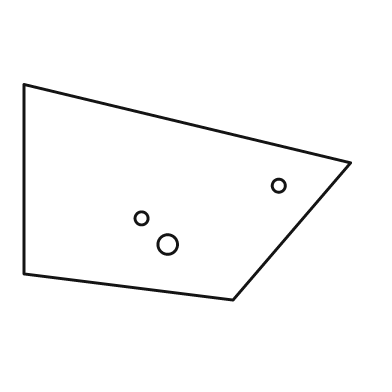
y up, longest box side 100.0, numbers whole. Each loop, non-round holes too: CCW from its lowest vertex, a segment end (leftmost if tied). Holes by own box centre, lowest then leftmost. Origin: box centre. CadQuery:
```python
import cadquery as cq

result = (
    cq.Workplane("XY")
    .moveTo(14.0, -33.0)
    .lineTo(50.0, 9.0)
    .lineTo(-50.0, 33.0)
    .lineTo(-50.0, -25.0)
    .close()
    .moveTo(-6.0, -16.0)
    .circle(3.0)
    .moveTo(-14.0, -8.0)
    .circle(2.0)
    .moveTo(28.0, 2.0)
    .circle(2.0)
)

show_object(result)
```